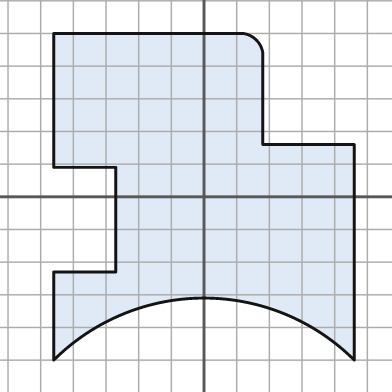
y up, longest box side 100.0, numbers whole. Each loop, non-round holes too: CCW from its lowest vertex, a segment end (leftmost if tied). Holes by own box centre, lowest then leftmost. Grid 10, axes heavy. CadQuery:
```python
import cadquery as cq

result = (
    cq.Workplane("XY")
    .moveTo(-46.0, -50.0)
    .threePointArc((0.0, -31.0), (46.0, -50.0))
    .lineTo(46.0, 16.0)
    .lineTo(18.0, 16.0)
    .lineTo(18.0, 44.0)
    .threePointArc((16.0, 48.0), (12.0, 50.0))
    .lineTo(-46.0, 50.0)
    .lineTo(-46.0, 9.0)
    .lineTo(-27.0, 9.0)
    .lineTo(-27.0, -23.0)
    .lineTo(-46.0, -23.0)
    .close()
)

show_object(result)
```